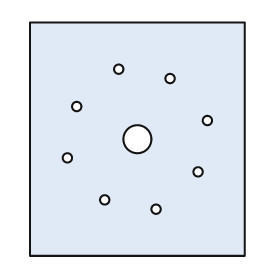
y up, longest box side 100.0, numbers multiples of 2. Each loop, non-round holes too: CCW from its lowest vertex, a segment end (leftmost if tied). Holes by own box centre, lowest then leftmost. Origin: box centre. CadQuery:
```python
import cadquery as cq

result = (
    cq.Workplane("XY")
    .moveTo(-46.0, -50.0)
    .lineTo(46.0, -50.0)
    .lineTo(46.0, 50.0)
    .lineTo(-46.0, 50.0)
    .close()
    .moveTo(8.0, -30.0)
    .circle(2.0)
    .moveTo(-14.0, -26.0)
    .circle(2.0)
    .moveTo(26.0, -14.0)
    .circle(2.0)
    .moveTo(-30.0, -8.0)
    .circle(2.0)
    .moveTo(0.0, 0.0)
    .circle(6.0)
    .moveTo(30.0, 8.0)
    .circle(2.0)
    .moveTo(-26.0, 14.0)
    .circle(2.0)
    .moveTo(14.0, 26.0)
    .circle(2.0)
    .moveTo(-8.0, 30.0)
    .circle(2.0)
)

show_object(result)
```